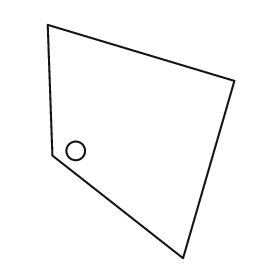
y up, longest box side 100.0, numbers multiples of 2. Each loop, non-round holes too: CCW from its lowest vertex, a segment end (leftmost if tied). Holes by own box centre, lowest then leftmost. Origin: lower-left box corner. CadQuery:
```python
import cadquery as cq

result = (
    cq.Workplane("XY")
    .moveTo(58.0, 0.0)
    .lineTo(80.0, 76.0)
    .lineTo(0.0, 100.0)
    .lineTo(2.0, 44.0)
    .close()
    .moveTo(12.0, 46.0)
    .circle(4.0)
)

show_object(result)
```